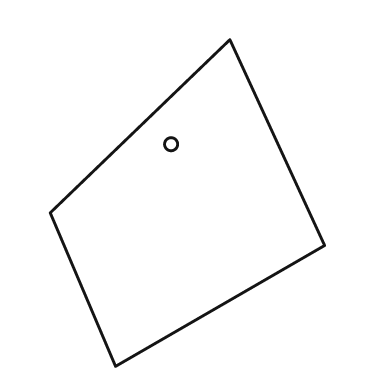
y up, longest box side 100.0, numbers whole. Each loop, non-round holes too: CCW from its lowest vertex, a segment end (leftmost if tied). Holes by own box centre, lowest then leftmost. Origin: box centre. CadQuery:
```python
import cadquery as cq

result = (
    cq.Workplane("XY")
    .moveTo(-22.0, -50.0)
    .lineTo(42.0, -13.0)
    .lineTo(13.0, 50.0)
    .lineTo(-42.0, -3.0)
    .close()
    .moveTo(-5.0, 18.0)
    .circle(2.0)
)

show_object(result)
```